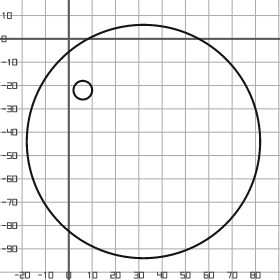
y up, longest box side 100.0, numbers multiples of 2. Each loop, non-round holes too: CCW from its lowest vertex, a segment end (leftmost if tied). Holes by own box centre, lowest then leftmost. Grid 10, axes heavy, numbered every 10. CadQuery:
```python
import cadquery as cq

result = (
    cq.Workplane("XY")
    .moveTo(32.0, -44.0)
    .circle(50.0)
    .moveTo(6.0, -22.0)
    .circle(4.0)
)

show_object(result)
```